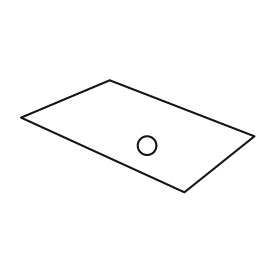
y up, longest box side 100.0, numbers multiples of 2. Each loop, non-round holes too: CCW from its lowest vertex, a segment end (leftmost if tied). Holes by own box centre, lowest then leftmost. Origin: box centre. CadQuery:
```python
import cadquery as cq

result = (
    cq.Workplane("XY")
    .moveTo(20.0, -24.0)
    .lineTo(50.0, 0.0)
    .lineTo(-12.0, 24.0)
    .lineTo(-50.0, 8.0)
    .close()
    .moveTo(4.0, -4.0)
    .circle(4.0)
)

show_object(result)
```